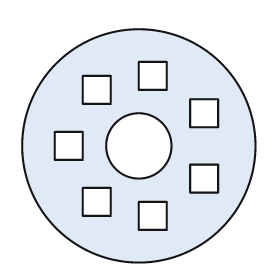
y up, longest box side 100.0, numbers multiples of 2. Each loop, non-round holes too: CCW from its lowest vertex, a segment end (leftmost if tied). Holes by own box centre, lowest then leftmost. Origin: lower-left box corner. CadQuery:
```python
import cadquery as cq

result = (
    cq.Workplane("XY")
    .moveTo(50.0, 50.0)
    .circle(50.0)
    .moveTo(50.0, 14.0)
    .lineTo(62.0, 14.0)
    .lineTo(62.0, 26.0)
    .lineTo(50.0, 26.0)
    .close()
    .moveTo(26.0, 20.0)
    .lineTo(38.0, 20.0)
    .lineTo(38.0, 32.0)
    .lineTo(26.0, 32.0)
    .close()
    .moveTo(72.0, 30.0)
    .lineTo(84.0, 30.0)
    .lineTo(84.0, 42.0)
    .lineTo(72.0, 42.0)
    .close()
    .moveTo(14.0, 44.0)
    .lineTo(26.0, 44.0)
    .lineTo(26.0, 56.0)
    .lineTo(14.0, 56.0)
    .close()
    .moveTo(50.0, 50.0)
    .circle(14.0)
    .moveTo(72.0, 58.0)
    .lineTo(84.0, 58.0)
    .lineTo(84.0, 70.0)
    .lineTo(72.0, 70.0)
    .close()
    .moveTo(26.0, 68.0)
    .lineTo(38.0, 68.0)
    .lineTo(38.0, 80.0)
    .lineTo(26.0, 80.0)
    .close()
    .moveTo(50.0, 74.0)
    .lineTo(62.0, 74.0)
    .lineTo(62.0, 86.0)
    .lineTo(50.0, 86.0)
    .close()
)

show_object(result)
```